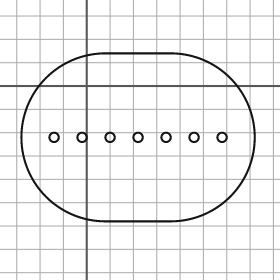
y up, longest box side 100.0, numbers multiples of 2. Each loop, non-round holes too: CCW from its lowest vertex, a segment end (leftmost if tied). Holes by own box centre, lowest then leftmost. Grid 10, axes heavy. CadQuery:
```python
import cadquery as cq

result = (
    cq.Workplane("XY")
    .moveTo(8.0, -58.0)
    .lineTo(36.0, -58.0)
    .threePointArc((72.0, -22.0), (36.0, 14.0))
    .lineTo(8.0, 14.0)
    .threePointArc((-28.0, -22.0), (8.0, -58.0))
    .close()
    .moveTo(-14.0, -22.0)
    .circle(2.0)
    .moveTo(-2.0, -22.0)
    .circle(2.0)
    .moveTo(10.0, -22.0)
    .circle(2.0)
    .moveTo(22.0, -22.0)
    .circle(2.0)
    .moveTo(34.0, -22.0)
    .circle(2.0)
    .moveTo(46.0, -22.0)
    .circle(2.0)
    .moveTo(58.0, -22.0)
    .circle(2.0)
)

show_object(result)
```